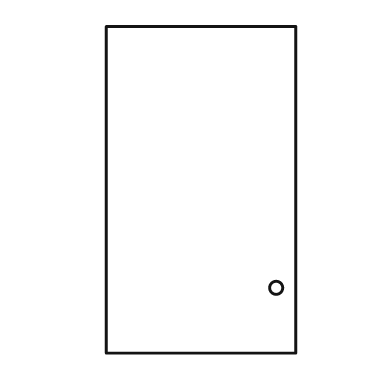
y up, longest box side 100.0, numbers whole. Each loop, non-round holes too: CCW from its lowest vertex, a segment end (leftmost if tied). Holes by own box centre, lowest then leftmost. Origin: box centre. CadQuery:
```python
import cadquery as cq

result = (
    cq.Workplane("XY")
    .moveTo(-29.0, -50.0)
    .lineTo(29.0, -50.0)
    .lineTo(29.0, 50.0)
    .lineTo(-29.0, 50.0)
    .close()
    .moveTo(23.0, -30.0)
    .circle(2.0)
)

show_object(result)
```